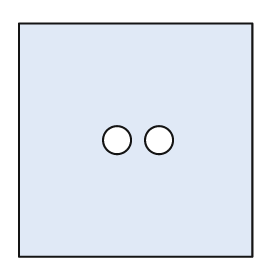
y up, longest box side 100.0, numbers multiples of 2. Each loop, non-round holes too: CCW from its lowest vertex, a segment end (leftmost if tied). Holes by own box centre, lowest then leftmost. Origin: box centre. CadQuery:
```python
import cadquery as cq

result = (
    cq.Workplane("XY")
    .moveTo(-50.0, -50.0)
    .lineTo(50.0, -50.0)
    .lineTo(50.0, 50.0)
    .lineTo(-50.0, 50.0)
    .close()
    .moveTo(-8.0, 0.0)
    .circle(6.0)
    .moveTo(10.0, 0.0)
    .circle(6.0)
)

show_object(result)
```